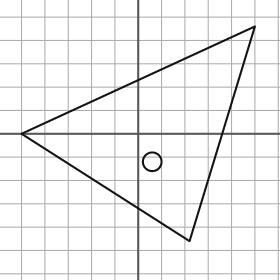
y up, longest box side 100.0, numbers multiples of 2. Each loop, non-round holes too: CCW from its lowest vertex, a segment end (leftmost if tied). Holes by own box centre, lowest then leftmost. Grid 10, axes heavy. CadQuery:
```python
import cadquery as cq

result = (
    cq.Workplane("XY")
    .moveTo(22.0, -46.0)
    .lineTo(50.0, 46.0)
    .lineTo(-50.0, 0.0)
    .close()
    .moveTo(6.0, -12.0)
    .circle(4.0)
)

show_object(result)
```